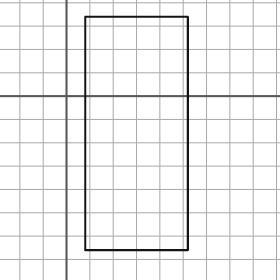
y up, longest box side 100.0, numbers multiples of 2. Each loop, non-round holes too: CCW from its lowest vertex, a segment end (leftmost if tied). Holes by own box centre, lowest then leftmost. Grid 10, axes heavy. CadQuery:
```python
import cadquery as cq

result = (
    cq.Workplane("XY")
    .moveTo(8.0, -66.0)
    .lineTo(52.0, -66.0)
    .lineTo(52.0, 34.0)
    .lineTo(8.0, 34.0)
    .close()
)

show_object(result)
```